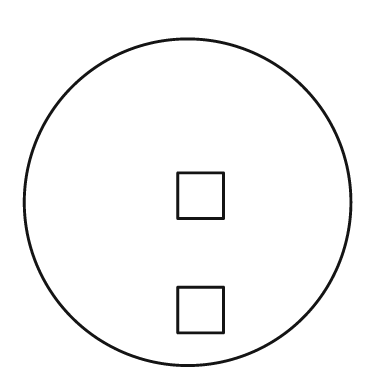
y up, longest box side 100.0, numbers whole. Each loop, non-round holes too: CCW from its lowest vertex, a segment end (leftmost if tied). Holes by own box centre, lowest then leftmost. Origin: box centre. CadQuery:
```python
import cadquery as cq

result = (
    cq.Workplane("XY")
    .moveTo(0.0, 0.0)
    .circle(50.0)
    .moveTo(-3.0, -40.0)
    .lineTo(11.0, -40.0)
    .lineTo(11.0, -26.0)
    .lineTo(-3.0, -26.0)
    .close()
    .moveTo(-3.0, -5.0)
    .lineTo(11.0, -5.0)
    .lineTo(11.0, 9.0)
    .lineTo(-3.0, 9.0)
    .close()
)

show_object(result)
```